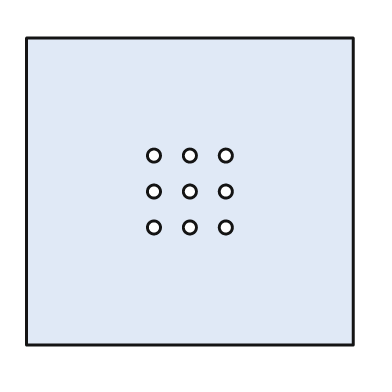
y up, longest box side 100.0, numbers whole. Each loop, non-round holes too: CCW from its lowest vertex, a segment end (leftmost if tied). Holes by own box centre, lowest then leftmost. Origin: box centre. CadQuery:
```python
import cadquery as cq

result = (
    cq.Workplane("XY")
    .moveTo(-50.0, -47.0)
    .lineTo(50.0, -47.0)
    .lineTo(50.0, 47.0)
    .lineTo(-50.0, 47.0)
    .close()
    .moveTo(-11.0, -11.0)
    .circle(2.0)
    .moveTo(0.0, -11.0)
    .circle(2.0)
    .moveTo(11.0, -11.0)
    .circle(2.0)
    .moveTo(-11.0, 0.0)
    .circle(2.0)
    .moveTo(0.0, 0.0)
    .circle(2.0)
    .moveTo(11.0, 0.0)
    .circle(2.0)
    .moveTo(-11.0, 11.0)
    .circle(2.0)
    .moveTo(0.0, 11.0)
    .circle(2.0)
    .moveTo(11.0, 11.0)
    .circle(2.0)
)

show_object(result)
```